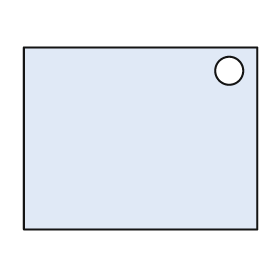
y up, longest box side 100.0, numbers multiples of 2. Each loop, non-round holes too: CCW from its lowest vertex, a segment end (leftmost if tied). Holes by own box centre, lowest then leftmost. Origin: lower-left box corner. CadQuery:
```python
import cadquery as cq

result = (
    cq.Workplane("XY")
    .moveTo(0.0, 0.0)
    .lineTo(100.0, 0.0)
    .lineTo(100.0, 78.0)
    .lineTo(0.0, 78.0)
    .close()
    .moveTo(88.0, 68.0)
    .circle(6.0)
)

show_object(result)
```